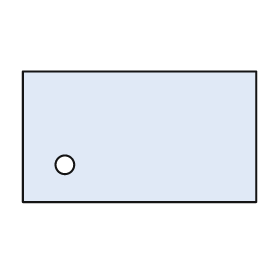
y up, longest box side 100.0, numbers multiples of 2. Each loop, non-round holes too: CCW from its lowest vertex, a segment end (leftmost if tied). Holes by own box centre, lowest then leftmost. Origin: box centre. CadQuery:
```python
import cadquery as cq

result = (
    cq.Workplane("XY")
    .moveTo(-50.0, -28.0)
    .lineTo(50.0, -28.0)
    .lineTo(50.0, 28.0)
    .lineTo(-50.0, 28.0)
    .close()
    .moveTo(-32.0, -12.0)
    .circle(4.0)
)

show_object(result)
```